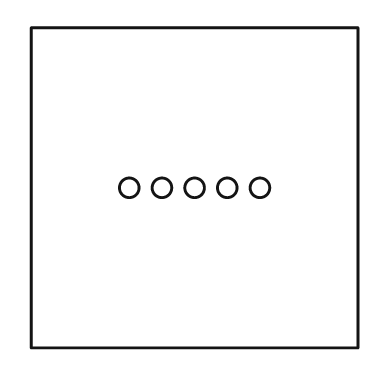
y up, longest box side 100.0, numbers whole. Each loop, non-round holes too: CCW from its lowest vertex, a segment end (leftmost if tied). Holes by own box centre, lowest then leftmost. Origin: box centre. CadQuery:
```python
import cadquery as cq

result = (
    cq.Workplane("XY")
    .moveTo(-50.0, -49.0)
    .lineTo(50.0, -49.0)
    .lineTo(50.0, 49.0)
    .lineTo(-50.0, 49.0)
    .close()
    .moveTo(-20.0, 0.0)
    .circle(3.0)
    .moveTo(-10.0, 0.0)
    .circle(3.0)
    .moveTo(0.0, 0.0)
    .circle(3.0)
    .moveTo(10.0, 0.0)
    .circle(3.0)
    .moveTo(20.0, 0.0)
    .circle(3.0)
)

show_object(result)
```